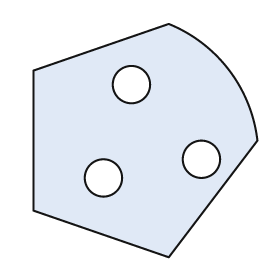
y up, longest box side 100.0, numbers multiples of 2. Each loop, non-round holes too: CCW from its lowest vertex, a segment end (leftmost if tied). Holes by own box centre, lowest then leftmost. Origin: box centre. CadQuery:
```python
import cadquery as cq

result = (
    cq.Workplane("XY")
    .moveTo(10.0, -50.0)
    .lineTo(48.0, 0.0)
    .threePointArc((36.0, 30.0), (10.0, 50.0))
    .lineTo(-48.0, 30.0)
    .lineTo(-48.0, -30.0)
    .close()
    .moveTo(-18.0, -16.0)
    .circle(8.0)
    .moveTo(24.0, -8.0)
    .circle(8.0)
    .moveTo(-6.0, 24.0)
    .circle(8.0)
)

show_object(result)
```